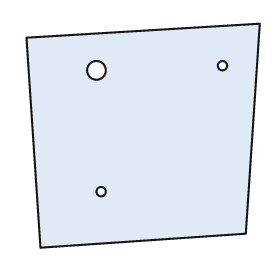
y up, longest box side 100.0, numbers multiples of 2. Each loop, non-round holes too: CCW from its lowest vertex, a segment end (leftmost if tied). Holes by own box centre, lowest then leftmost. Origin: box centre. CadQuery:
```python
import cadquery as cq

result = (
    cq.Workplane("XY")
    .moveTo(-44.0, -48.0)
    .lineTo(44.0, -42.0)
    .lineTo(50.0, 48.0)
    .lineTo(-50.0, 42.0)
    .close()
    .moveTo(-18.0, -24.0)
    .circle(2.0)
    .moveTo(-20.0, 28.0)
    .circle(4.0)
    .moveTo(34.0, 30.0)
    .circle(2.0)
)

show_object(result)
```